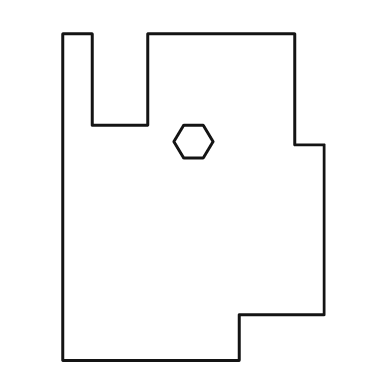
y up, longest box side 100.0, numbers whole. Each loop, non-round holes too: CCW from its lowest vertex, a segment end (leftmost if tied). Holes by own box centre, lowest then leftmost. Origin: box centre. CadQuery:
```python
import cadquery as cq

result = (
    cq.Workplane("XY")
    .moveTo(-40.0, -50.0)
    .lineTo(14.0, -50.0)
    .lineTo(14.0, -36.0)
    .lineTo(40.0, -36.0)
    .lineTo(40.0, 16.0)
    .lineTo(31.0, 16.0)
    .lineTo(31.0, 50.0)
    .lineTo(-14.0, 50.0)
    .lineTo(-14.0, 22.0)
    .lineTo(-31.0, 22.0)
    .lineTo(-31.0, 50.0)
    .lineTo(-40.0, 50.0)
    .close()
    .moveTo(-3.0, 12.0)
    .lineTo(3.0, 12.0)
    .lineTo(6.0, 17.0)
    .lineTo(3.0, 22.0)
    .lineTo(-3.0, 22.0)
    .lineTo(-6.0, 17.0)
    .close()
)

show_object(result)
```